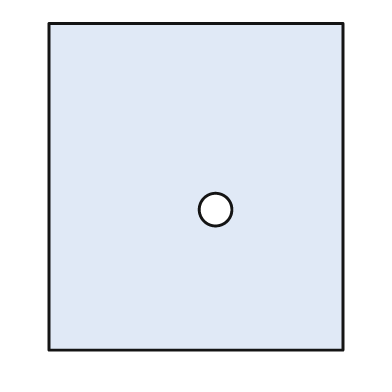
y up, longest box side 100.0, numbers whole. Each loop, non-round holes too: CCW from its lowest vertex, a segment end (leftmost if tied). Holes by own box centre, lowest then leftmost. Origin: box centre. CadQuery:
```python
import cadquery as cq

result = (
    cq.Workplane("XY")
    .moveTo(-45.0, -50.0)
    .lineTo(45.0, -50.0)
    .lineTo(45.0, 50.0)
    .lineTo(-45.0, 50.0)
    .close()
    .moveTo(6.0, -7.0)
    .circle(5.0)
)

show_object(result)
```